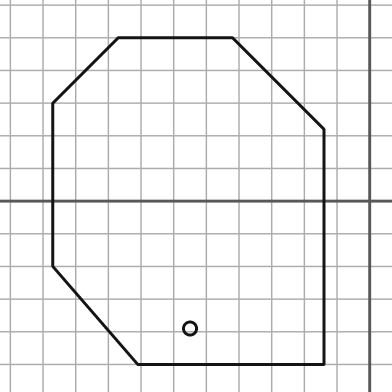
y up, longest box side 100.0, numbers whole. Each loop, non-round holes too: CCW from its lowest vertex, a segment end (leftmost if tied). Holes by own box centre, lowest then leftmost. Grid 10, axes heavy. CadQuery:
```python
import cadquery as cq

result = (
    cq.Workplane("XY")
    .moveTo(-71.0, -50.0)
    .lineTo(-14.0, -50.0)
    .lineTo(-14.0, 22.0)
    .lineTo(-42.0, 50.0)
    .lineTo(-77.0, 50.0)
    .lineTo(-97.0, 30.0)
    .lineTo(-97.0, -20.0)
    .close()
    .moveTo(-55.0, -39.0)
    .circle(2.0)
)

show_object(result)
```